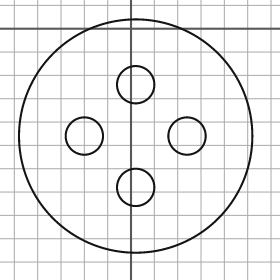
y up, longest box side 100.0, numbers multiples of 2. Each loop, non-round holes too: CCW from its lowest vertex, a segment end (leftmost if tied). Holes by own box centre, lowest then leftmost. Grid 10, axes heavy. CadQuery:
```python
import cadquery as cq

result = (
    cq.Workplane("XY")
    .moveTo(2.0, -46.0)
    .circle(50.0)
    .moveTo(2.0, -68.0)
    .circle(8.0)
    .moveTo(-20.0, -46.0)
    .circle(8.0)
    .moveTo(24.0, -46.0)
    .circle(8.0)
    .moveTo(2.0, -24.0)
    .circle(8.0)
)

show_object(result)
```